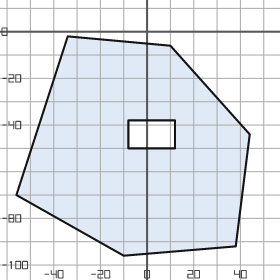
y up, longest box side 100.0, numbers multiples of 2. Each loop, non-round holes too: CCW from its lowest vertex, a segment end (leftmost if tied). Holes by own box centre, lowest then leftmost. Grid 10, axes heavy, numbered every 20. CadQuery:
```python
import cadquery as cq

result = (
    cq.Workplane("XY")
    .moveTo(-10.0, -96.0)
    .lineTo(38.0, -92.0)
    .lineTo(44.0, -44.0)
    .lineTo(10.0, -6.0)
    .lineTo(-34.0, -2.0)
    .lineTo(-56.0, -70.0)
    .close()
    .moveTo(-8.0, -50.0)
    .lineTo(12.0, -50.0)
    .lineTo(12.0, -38.0)
    .lineTo(-8.0, -38.0)
    .close()
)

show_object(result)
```